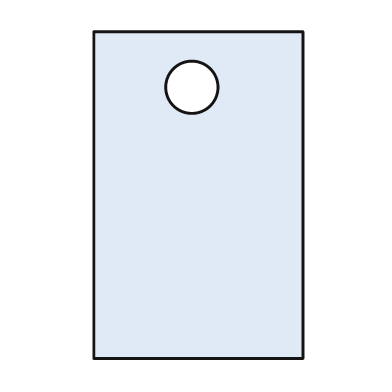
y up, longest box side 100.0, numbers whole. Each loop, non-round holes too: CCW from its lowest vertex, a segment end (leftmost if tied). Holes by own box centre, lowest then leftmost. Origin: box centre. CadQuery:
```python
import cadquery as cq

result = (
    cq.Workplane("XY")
    .moveTo(-32.0, -50.0)
    .lineTo(32.0, -50.0)
    .lineTo(32.0, 50.0)
    .lineTo(-32.0, 50.0)
    .close()
    .moveTo(-2.0, 33.0)
    .circle(8.0)
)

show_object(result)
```